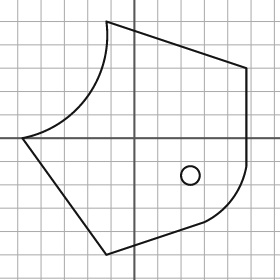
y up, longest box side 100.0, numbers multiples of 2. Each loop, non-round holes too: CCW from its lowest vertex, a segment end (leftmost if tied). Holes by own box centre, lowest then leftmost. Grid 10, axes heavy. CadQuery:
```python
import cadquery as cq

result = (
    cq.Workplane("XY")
    .moveTo(-12.0, -50.0)
    .lineTo(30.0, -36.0)
    .threePointArc((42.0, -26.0), (48.0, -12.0))
    .lineTo(48.0, 30.0)
    .lineTo(-12.0, 50.0)
    .threePointArc((-20.0, 18.0), (-48.0, 0.0))
    .close()
    .moveTo(24.0, -16.0)
    .circle(4.0)
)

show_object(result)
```